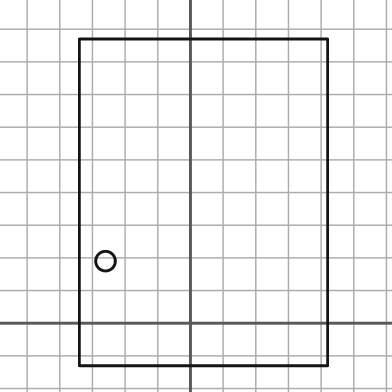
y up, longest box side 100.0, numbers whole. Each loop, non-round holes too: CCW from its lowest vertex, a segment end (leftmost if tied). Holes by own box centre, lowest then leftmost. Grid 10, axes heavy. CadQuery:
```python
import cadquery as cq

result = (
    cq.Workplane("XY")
    .moveTo(-34.0, -13.0)
    .lineTo(42.0, -13.0)
    .lineTo(42.0, 87.0)
    .lineTo(-34.0, 87.0)
    .close()
    .moveTo(-26.0, 19.0)
    .circle(3.0)
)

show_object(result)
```